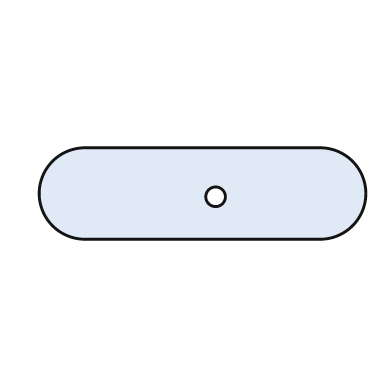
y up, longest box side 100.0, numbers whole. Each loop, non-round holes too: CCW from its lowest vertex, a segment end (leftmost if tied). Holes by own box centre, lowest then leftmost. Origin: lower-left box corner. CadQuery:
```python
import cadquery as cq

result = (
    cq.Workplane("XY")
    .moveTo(14.0, 0.0)
    .lineTo(86.0, 0.0)
    .threePointArc((100.0, 14.0), (86.0, 28.0))
    .lineTo(14.0, 28.0)
    .threePointArc((0.0, 14.0), (14.0, 0.0))
    .close()
    .moveTo(54.0, 13.0)
    .circle(3.0)
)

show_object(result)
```